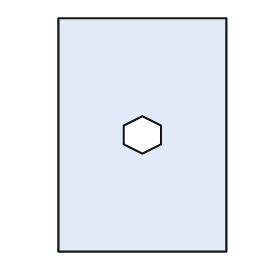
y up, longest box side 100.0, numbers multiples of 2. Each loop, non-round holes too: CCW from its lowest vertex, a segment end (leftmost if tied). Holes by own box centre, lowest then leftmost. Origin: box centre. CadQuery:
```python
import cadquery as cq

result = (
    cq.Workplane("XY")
    .moveTo(-36.0, -50.0)
    .lineTo(36.0, -50.0)
    .lineTo(36.0, 50.0)
    .lineTo(-36.0, 50.0)
    .close()
    .moveTo(0.0, -8.0)
    .lineTo(8.0, -4.0)
    .lineTo(8.0, 4.0)
    .lineTo(0.0, 8.0)
    .lineTo(-8.0, 4.0)
    .lineTo(-8.0, -4.0)
    .close()
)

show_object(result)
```